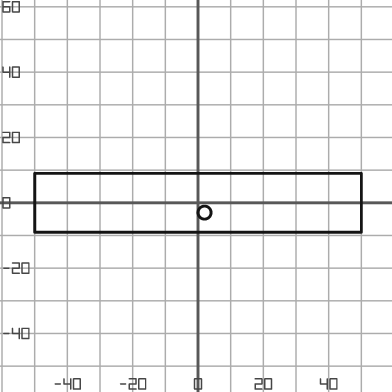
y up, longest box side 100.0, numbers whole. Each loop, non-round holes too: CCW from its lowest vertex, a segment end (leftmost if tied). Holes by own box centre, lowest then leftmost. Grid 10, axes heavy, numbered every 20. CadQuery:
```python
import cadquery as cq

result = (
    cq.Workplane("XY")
    .moveTo(-50.0, -9.0)
    .lineTo(50.0, -9.0)
    .lineTo(50.0, 9.0)
    .lineTo(-50.0, 9.0)
    .close()
    .moveTo(2.0, -3.0)
    .circle(2.0)
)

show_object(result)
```